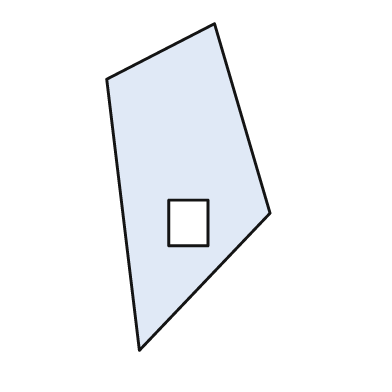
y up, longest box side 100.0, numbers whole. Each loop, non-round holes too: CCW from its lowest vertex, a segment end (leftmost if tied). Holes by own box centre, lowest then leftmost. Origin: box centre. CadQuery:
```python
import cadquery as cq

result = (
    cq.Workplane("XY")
    .moveTo(-15.0, -50.0)
    .lineTo(25.0, -8.0)
    .lineTo(8.0, 50.0)
    .lineTo(-25.0, 33.0)
    .close()
    .moveTo(-6.0, -18.0)
    .lineTo(6.0, -18.0)
    .lineTo(6.0, -4.0)
    .lineTo(-6.0, -4.0)
    .close()
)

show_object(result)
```